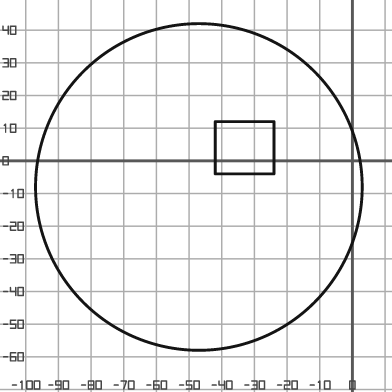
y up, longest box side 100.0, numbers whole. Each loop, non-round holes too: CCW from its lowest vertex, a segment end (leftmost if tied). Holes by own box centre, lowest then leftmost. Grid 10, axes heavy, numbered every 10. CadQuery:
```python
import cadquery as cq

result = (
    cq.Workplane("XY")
    .moveTo(-47.0, -8.0)
    .circle(50.0)
    .moveTo(-42.0, -4.0)
    .lineTo(-24.0, -4.0)
    .lineTo(-24.0, 12.0)
    .lineTo(-42.0, 12.0)
    .close()
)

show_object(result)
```